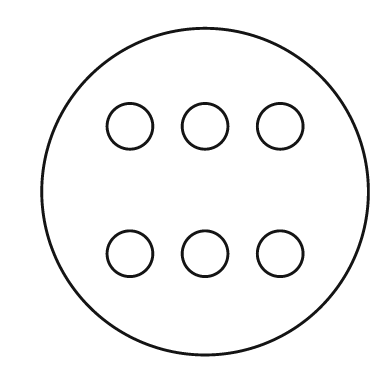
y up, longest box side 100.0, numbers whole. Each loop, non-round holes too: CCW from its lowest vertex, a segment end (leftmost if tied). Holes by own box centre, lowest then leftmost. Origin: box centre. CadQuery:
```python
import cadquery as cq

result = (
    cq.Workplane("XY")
    .moveTo(0.0, 0.0)
    .circle(50.0)
    .moveTo(-23.0, -19.0)
    .circle(7.0)
    .moveTo(0.0, -19.0)
    .circle(7.0)
    .moveTo(23.0, -19.0)
    .circle(7.0)
    .moveTo(-23.0, 20.0)
    .circle(7.0)
    .moveTo(0.0, 20.0)
    .circle(7.0)
    .moveTo(23.0, 20.0)
    .circle(7.0)
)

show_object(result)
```